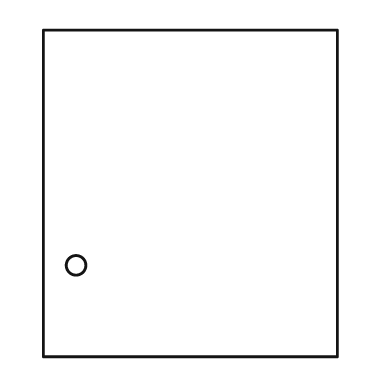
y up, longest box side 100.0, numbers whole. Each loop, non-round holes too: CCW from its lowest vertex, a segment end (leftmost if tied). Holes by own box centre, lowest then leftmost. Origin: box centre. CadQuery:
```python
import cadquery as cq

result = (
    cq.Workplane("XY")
    .moveTo(-45.0, -50.0)
    .lineTo(45.0, -50.0)
    .lineTo(45.0, 50.0)
    .lineTo(-45.0, 50.0)
    .close()
    .moveTo(-35.0, -22.0)
    .circle(3.0)
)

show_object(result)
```